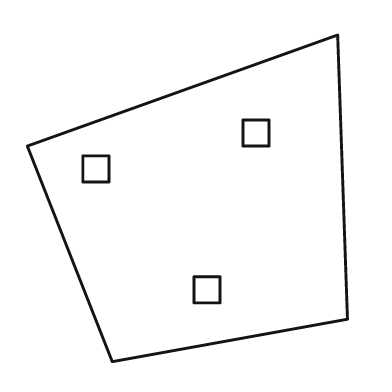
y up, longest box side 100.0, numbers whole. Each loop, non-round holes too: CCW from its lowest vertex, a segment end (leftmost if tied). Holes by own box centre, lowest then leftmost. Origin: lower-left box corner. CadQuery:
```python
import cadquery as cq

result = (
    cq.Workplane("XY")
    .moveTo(26.0, 0.0)
    .lineTo(98.0, 13.0)
    .lineTo(95.0, 100.0)
    .lineTo(0.0, 66.0)
    .close()
    .moveTo(51.0, 18.0)
    .lineTo(59.0, 18.0)
    .lineTo(59.0, 26.0)
    .lineTo(51.0, 26.0)
    .close()
    .moveTo(17.0, 55.0)
    .lineTo(25.0, 55.0)
    .lineTo(25.0, 63.0)
    .lineTo(17.0, 63.0)
    .close()
    .moveTo(66.0, 66.0)
    .lineTo(74.0, 66.0)
    .lineTo(74.0, 74.0)
    .lineTo(66.0, 74.0)
    .close()
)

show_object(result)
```